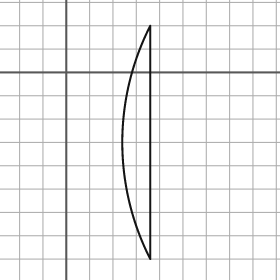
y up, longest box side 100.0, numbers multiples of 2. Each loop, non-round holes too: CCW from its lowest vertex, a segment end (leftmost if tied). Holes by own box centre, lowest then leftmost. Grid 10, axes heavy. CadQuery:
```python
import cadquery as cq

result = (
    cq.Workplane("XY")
    .moveTo(36.0, -80.0)
    .lineTo(36.0, 20.0)
    .threePointArc((24.0, -30.0), (36.0, -80.0))
    .close()
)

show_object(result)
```